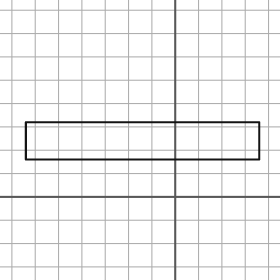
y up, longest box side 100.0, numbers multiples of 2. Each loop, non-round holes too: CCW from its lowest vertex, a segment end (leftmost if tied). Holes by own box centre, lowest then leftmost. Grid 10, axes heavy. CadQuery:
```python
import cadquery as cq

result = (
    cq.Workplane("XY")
    .moveTo(-64.0, 16.0)
    .lineTo(36.0, 16.0)
    .lineTo(36.0, 32.0)
    .lineTo(-64.0, 32.0)
    .close()
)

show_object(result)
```